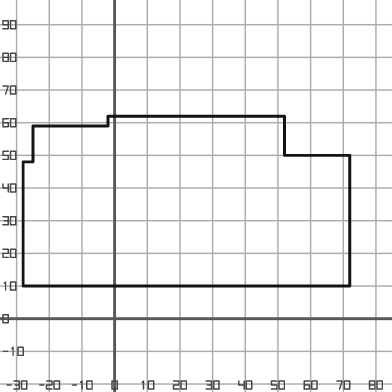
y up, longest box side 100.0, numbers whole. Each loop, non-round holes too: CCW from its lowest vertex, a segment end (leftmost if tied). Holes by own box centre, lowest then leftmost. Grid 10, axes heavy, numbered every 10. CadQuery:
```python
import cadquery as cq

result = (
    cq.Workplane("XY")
    .moveTo(-28.0, 10.0)
    .lineTo(72.0, 10.0)
    .lineTo(72.0, 50.0)
    .lineTo(52.0, 50.0)
    .lineTo(52.0, 62.0)
    .lineTo(-2.0, 62.0)
    .lineTo(-2.0, 59.0)
    .lineTo(-25.0, 59.0)
    .lineTo(-25.0, 48.0)
    .lineTo(-28.0, 48.0)
    .close()
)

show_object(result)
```